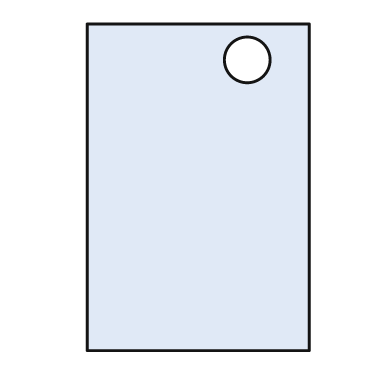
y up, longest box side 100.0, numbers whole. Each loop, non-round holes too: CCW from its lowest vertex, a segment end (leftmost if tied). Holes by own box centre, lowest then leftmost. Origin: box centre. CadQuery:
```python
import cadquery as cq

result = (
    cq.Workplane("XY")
    .moveTo(-34.0, -50.0)
    .lineTo(34.0, -50.0)
    .lineTo(34.0, 50.0)
    .lineTo(-34.0, 50.0)
    .close()
    .moveTo(15.0, 39.0)
    .circle(7.0)
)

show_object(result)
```